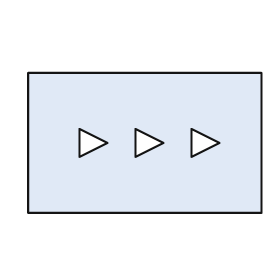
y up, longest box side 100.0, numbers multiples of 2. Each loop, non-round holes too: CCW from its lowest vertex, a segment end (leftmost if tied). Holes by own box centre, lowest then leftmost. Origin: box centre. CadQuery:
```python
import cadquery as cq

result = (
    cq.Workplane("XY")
    .moveTo(-50.0, -30.0)
    .lineTo(50.0, -30.0)
    .lineTo(50.0, 30.0)
    .lineTo(-50.0, 30.0)
    .close()
    .moveTo(-28.0, -6.0)
    .lineTo(-16.0, 0.0)
    .lineTo(-28.0, 6.0)
    .close()
    .moveTo(-4.0, -6.0)
    .lineTo(8.0, 0.0)
    .lineTo(-4.0, 6.0)
    .close()
    .moveTo(20.0, -6.0)
    .lineTo(32.0, 0.0)
    .lineTo(20.0, 6.0)
    .close()
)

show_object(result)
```